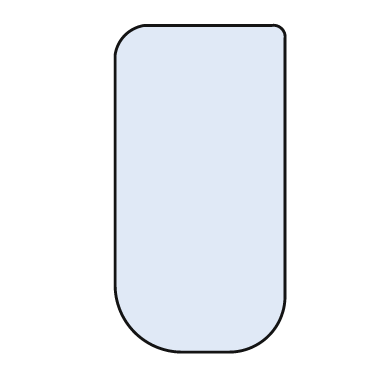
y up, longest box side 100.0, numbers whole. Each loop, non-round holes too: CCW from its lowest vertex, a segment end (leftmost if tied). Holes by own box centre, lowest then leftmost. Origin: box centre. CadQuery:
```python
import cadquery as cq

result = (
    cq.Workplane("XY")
    .moveTo(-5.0, -50.0)
    .lineTo(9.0, -50.0)
    .threePointArc((21.0, -45.0), (26.0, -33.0))
    .lineTo(26.0, 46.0)
    .threePointArc((25.0, 49.0), (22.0, 50.0))
    .lineTo(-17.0, 50.0)
    .threePointArc((-23.0, 47.0), (-26.0, 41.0))
    .lineTo(-26.0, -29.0)
    .threePointArc((-20.0, -44.0), (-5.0, -50.0))
    .close()
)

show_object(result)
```